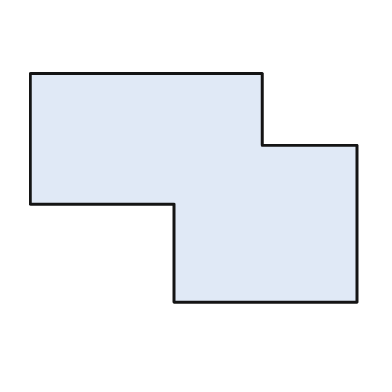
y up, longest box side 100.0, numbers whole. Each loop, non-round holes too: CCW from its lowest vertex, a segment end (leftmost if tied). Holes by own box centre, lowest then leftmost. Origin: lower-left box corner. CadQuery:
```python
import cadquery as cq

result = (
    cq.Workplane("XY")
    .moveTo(44.0, 0.0)
    .lineTo(100.0, 0.0)
    .lineTo(100.0, 48.0)
    .lineTo(71.0, 48.0)
    .lineTo(71.0, 70.0)
    .lineTo(0.0, 70.0)
    .lineTo(0.0, 30.0)
    .lineTo(44.0, 30.0)
    .close()
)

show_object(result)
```